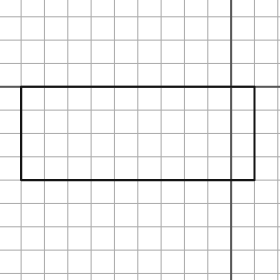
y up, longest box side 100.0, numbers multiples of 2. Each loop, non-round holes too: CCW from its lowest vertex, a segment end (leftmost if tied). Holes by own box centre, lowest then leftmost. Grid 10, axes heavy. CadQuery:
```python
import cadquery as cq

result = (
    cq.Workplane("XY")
    .moveTo(-90.0, -40.0)
    .lineTo(10.0, -40.0)
    .lineTo(10.0, 0.0)
    .lineTo(-90.0, 0.0)
    .close()
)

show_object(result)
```